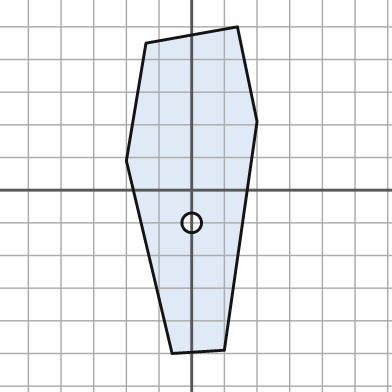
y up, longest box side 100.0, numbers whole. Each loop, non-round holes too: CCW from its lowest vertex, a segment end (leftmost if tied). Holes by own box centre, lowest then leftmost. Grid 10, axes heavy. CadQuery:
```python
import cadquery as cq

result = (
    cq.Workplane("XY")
    .moveTo(-6.0, -50.0)
    .lineTo(10.0, -49.0)
    .lineTo(20.0, 21.0)
    .lineTo(14.0, 50.0)
    .lineTo(-14.0, 45.0)
    .lineTo(-20.0, 9.0)
    .close()
    .moveTo(0.0, -10.0)
    .circle(3.0)
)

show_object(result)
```